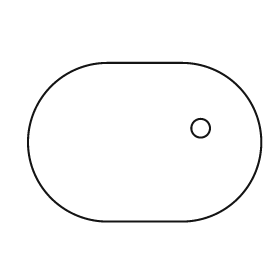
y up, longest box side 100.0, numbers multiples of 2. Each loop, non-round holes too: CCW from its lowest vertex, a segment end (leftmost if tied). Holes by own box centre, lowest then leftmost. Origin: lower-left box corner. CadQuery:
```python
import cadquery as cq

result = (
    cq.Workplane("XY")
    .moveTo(34.0, 0.0)
    .lineTo(66.0, 0.0)
    .threePointArc((100.0, 34.0), (66.0, 68.0))
    .lineTo(34.0, 68.0)
    .threePointArc((0.0, 34.0), (34.0, 0.0))
    .close()
    .moveTo(74.0, 40.0)
    .circle(4.0)
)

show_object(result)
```